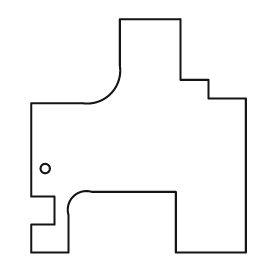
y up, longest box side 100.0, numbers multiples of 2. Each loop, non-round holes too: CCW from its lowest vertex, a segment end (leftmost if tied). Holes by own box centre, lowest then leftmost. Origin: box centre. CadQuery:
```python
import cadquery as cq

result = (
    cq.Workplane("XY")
    .moveTo(-46.0, -50.0)
    .lineTo(-30.0, -50.0)
    .lineTo(-30.0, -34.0)
    .threePointArc((-28.0, -26.0), (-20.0, -24.0))
    .lineTo(16.0, -24.0)
    .lineTo(16.0, -50.0)
    .lineTo(46.0, -50.0)
    .lineTo(46.0, 16.0)
    .lineTo(30.0, 16.0)
    .lineTo(30.0, 24.0)
    .lineTo(18.0, 24.0)
    .lineTo(18.0, 50.0)
    .lineTo(-8.0, 50.0)
    .lineTo(-8.0, 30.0)
    .threePointArc((-12.0, 18.0), (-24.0, 14.0))
    .lineTo(-46.0, 14.0)
    .lineTo(-46.0, -26.0)
    .lineTo(-36.0, -26.0)
    .lineTo(-36.0, -38.0)
    .lineTo(-46.0, -38.0)
    .close()
    .moveTo(-40.0, -14.0)
    .circle(2.0)
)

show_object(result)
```